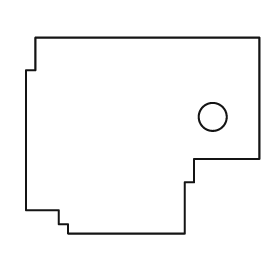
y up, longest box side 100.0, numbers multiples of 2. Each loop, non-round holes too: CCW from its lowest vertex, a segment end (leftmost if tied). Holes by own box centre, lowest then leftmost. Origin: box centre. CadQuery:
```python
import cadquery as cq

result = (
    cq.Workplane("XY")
    .moveTo(-32.0, -42.0)
    .lineTo(18.0, -42.0)
    .lineTo(18.0, -20.0)
    .lineTo(22.0, -20.0)
    .lineTo(22.0, -10.0)
    .lineTo(50.0, -10.0)
    .lineTo(50.0, 42.0)
    .lineTo(-46.0, 42.0)
    .lineTo(-46.0, 28.0)
    .lineTo(-50.0, 28.0)
    .lineTo(-50.0, -32.0)
    .lineTo(-36.0, -32.0)
    .lineTo(-36.0, -38.0)
    .lineTo(-32.0, -38.0)
    .close()
    .moveTo(30.0, 8.0)
    .circle(6.0)
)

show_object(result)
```